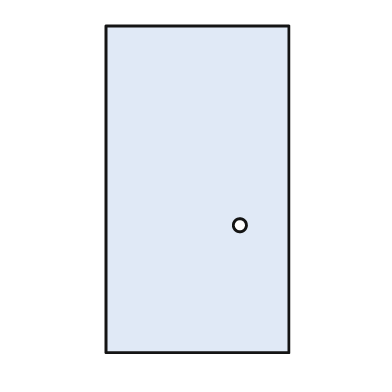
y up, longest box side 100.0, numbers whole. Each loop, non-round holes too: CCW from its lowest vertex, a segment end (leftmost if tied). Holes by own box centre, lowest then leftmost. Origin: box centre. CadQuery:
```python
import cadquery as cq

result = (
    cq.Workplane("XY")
    .moveTo(-28.0, -50.0)
    .lineTo(28.0, -50.0)
    .lineTo(28.0, 50.0)
    .lineTo(-28.0, 50.0)
    .close()
    .moveTo(13.0, -11.0)
    .circle(2.0)
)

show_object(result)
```